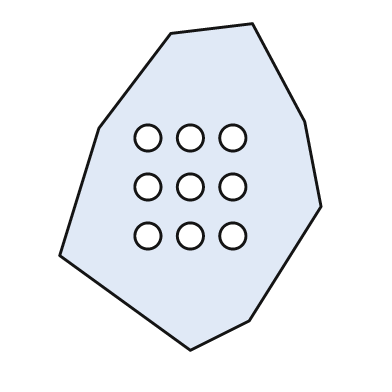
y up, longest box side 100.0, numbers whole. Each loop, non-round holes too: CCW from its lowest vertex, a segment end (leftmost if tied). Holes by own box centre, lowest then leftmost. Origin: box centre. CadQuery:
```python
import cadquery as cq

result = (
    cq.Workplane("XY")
    .moveTo(0.0, -50.0)
    .lineTo(18.0, -41.0)
    .lineTo(40.0, -6.0)
    .lineTo(35.0, 20.0)
    .lineTo(19.0, 50.0)
    .lineTo(-6.0, 47.0)
    .lineTo(-28.0, 18.0)
    .lineTo(-40.0, -21.0)
    .close()
    .moveTo(-13.0, -15.0)
    .circle(4.0)
    .moveTo(0.0, -15.0)
    .circle(4.0)
    .moveTo(13.0, -15.0)
    .circle(4.0)
    .moveTo(-13.0, 0.0)
    .circle(4.0)
    .moveTo(0.0, 0.0)
    .circle(4.0)
    .moveTo(13.0, 0.0)
    .circle(4.0)
    .moveTo(-13.0, 15.0)
    .circle(4.0)
    .moveTo(0.0, 15.0)
    .circle(4.0)
    .moveTo(13.0, 15.0)
    .circle(4.0)
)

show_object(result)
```